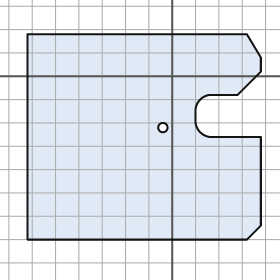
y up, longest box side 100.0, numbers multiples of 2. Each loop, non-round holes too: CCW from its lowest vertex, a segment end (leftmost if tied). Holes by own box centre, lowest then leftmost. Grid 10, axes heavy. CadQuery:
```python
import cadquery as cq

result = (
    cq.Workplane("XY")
    .moveTo(-62.0, -70.0)
    .lineTo(32.0, -70.0)
    .lineTo(38.0, -64.0)
    .lineTo(38.0, -26.0)
    .lineTo(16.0, -26.0)
    .threePointArc((12.0, -24.0), (10.0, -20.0))
    .lineTo(10.0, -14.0)
    .threePointArc((12.0, -10.0), (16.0, -8.0))
    .lineTo(28.0, -8.0)
    .lineTo(38.0, 2.0)
    .lineTo(38.0, 8.0)
    .lineTo(32.0, 18.0)
    .lineTo(-62.0, 18.0)
    .close()
    .moveTo(-4.0, -22.0)
    .circle(2.0)
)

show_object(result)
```